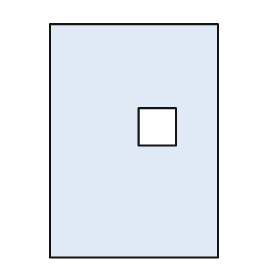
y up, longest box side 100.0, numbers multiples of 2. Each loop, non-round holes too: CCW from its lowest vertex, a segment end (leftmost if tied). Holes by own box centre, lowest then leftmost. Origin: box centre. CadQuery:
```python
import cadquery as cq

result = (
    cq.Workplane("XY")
    .moveTo(-36.0, -50.0)
    .lineTo(36.0, -50.0)
    .lineTo(36.0, 50.0)
    .lineTo(-36.0, 50.0)
    .close()
    .moveTo(2.0, -2.0)
    .lineTo(18.0, -2.0)
    .lineTo(18.0, 14.0)
    .lineTo(2.0, 14.0)
    .close()
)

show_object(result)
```